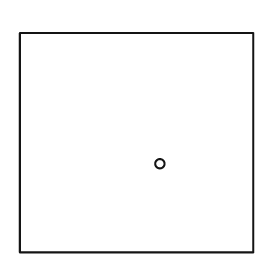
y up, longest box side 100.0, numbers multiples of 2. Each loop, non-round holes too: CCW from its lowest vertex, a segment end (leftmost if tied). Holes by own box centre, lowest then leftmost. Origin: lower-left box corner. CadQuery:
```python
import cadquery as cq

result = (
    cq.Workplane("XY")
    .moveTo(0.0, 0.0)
    .lineTo(100.0, 0.0)
    .lineTo(100.0, 94.0)
    .lineTo(0.0, 94.0)
    .close()
    .moveTo(60.0, 38.0)
    .circle(2.0)
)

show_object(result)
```